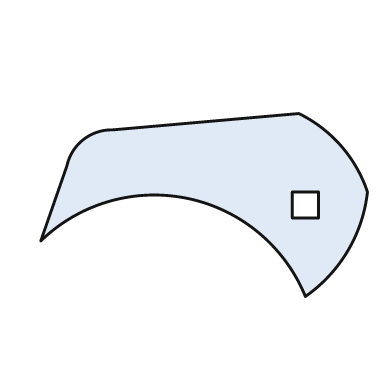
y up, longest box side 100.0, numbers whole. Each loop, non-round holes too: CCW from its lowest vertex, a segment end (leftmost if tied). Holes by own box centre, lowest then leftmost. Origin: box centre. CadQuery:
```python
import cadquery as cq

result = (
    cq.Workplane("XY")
    .moveTo(31.0, -28.0)
    .threePointArc((44.0, -14.0), (50.0, 4.0))
    .threePointArc((42.0, 18.0), (29.0, 28.0))
    .lineTo(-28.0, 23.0)
    .threePointArc((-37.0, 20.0), (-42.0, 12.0))
    .lineTo(-50.0, -11.0)
    .threePointArc((-5.0, 2.0), (31.0, -28.0))
    .close()
    .moveTo(27.0, -4.0)
    .lineTo(35.0, -4.0)
    .lineTo(35.0, 4.0)
    .lineTo(27.0, 4.0)
    .close()
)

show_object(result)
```